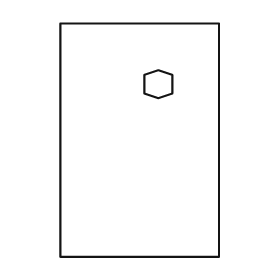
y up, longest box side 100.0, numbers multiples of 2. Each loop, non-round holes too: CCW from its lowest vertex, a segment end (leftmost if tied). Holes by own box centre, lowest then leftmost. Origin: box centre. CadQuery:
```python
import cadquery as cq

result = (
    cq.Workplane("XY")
    .moveTo(-34.0, -50.0)
    .lineTo(34.0, -50.0)
    .lineTo(34.0, 50.0)
    .lineTo(-34.0, 50.0)
    .close()
    .moveTo(8.0, 18.0)
    .lineTo(14.0, 20.0)
    .lineTo(14.0, 28.0)
    .lineTo(8.0, 30.0)
    .lineTo(2.0, 28.0)
    .lineTo(2.0, 20.0)
    .close()
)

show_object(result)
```